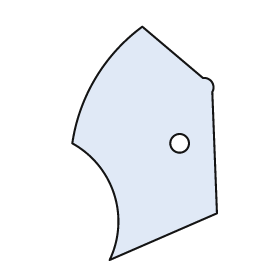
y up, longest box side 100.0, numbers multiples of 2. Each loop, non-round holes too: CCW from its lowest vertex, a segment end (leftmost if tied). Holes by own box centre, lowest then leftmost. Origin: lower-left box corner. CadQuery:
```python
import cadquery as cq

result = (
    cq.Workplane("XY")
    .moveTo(16.0, 0.0)
    .lineTo(62.0, 20.0)
    .lineTo(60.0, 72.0)
    .threePointArc((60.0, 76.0), (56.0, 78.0))
    .lineTo(30.0, 100.0)
    .threePointArc((10.0, 78.0), (0.0, 50.0))
    .threePointArc((18.0, 28.0), (16.0, 0.0))
    .close()
    .moveTo(46.0, 50.0)
    .circle(4.0)
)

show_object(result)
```